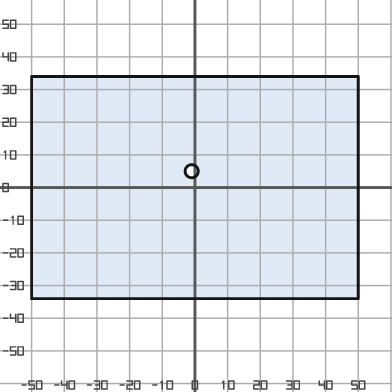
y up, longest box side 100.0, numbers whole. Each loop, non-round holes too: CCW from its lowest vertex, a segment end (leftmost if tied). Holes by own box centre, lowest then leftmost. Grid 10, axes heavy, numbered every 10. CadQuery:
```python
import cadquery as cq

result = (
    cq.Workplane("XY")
    .moveTo(-50.0, -34.0)
    .lineTo(50.0, -34.0)
    .lineTo(50.0, 34.0)
    .lineTo(-50.0, 34.0)
    .close()
    .moveTo(-1.0, 5.0)
    .circle(2.0)
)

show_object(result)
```